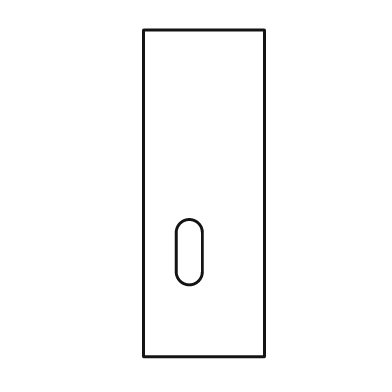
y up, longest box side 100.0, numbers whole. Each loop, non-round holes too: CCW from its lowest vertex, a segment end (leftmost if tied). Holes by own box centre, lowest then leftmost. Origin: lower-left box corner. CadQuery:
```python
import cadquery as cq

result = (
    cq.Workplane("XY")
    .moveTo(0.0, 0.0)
    .lineTo(37.0, 0.0)
    .lineTo(37.0, 100.0)
    .lineTo(0.0, 100.0)
    .close()
    .moveTo(10.0, 26.0)
    .threePointArc((14.0, 22.0), (18.0, 26.0))
    .lineTo(18.0, 38.0)
    .threePointArc((14.0, 42.0), (10.0, 38.0))
    .close()
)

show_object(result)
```